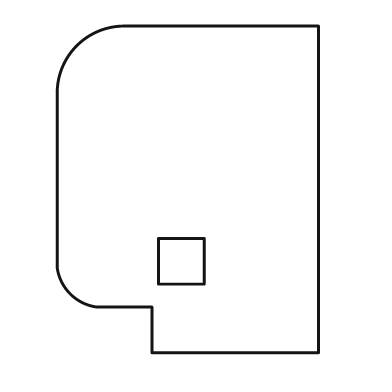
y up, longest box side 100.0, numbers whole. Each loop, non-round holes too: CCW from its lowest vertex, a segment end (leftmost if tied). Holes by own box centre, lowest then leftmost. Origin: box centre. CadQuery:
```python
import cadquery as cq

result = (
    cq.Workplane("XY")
    .moveTo(-11.0, -50.0)
    .lineTo(40.0, -50.0)
    .lineTo(40.0, 50.0)
    .lineTo(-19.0, 50.0)
    .threePointArc((-34.0, 44.0), (-40.0, 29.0))
    .lineTo(-40.0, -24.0)
    .threePointArc((-36.0, -32.0), (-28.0, -36.0))
    .lineTo(-11.0, -36.0)
    .close()
    .moveTo(-9.0, -29.0)
    .lineTo(5.0, -29.0)
    .lineTo(5.0, -15.0)
    .lineTo(-9.0, -15.0)
    .close()
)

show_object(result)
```